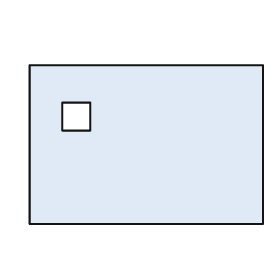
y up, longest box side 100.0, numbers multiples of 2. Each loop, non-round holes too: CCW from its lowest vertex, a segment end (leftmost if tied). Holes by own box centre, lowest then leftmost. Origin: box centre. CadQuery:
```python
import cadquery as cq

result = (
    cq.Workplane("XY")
    .moveTo(-50.0, -34.0)
    .lineTo(50.0, -34.0)
    .lineTo(50.0, 34.0)
    .lineTo(-50.0, 34.0)
    .close()
    .moveTo(-36.0, 6.0)
    .lineTo(-24.0, 6.0)
    .lineTo(-24.0, 18.0)
    .lineTo(-36.0, 18.0)
    .close()
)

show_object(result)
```